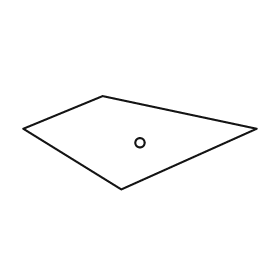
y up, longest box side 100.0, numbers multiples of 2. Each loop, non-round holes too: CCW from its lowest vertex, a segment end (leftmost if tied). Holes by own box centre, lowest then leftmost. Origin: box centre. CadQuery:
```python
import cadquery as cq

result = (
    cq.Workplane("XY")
    .moveTo(-8.0, -20.0)
    .lineTo(50.0, 6.0)
    .lineTo(-16.0, 20.0)
    .lineTo(-50.0, 6.0)
    .close()
    .moveTo(0.0, 0.0)
    .circle(2.0)
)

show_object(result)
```